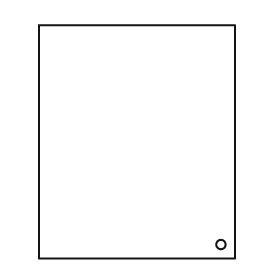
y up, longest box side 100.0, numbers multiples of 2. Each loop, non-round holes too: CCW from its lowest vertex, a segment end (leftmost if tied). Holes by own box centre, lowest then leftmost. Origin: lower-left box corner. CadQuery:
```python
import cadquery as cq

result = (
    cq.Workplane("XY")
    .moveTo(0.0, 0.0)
    .lineTo(84.0, 0.0)
    .lineTo(84.0, 100.0)
    .lineTo(0.0, 100.0)
    .close()
    .moveTo(78.0, 6.0)
    .circle(2.0)
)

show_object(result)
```